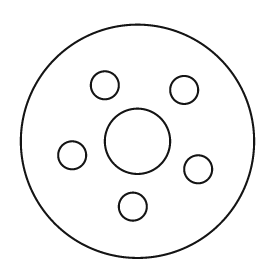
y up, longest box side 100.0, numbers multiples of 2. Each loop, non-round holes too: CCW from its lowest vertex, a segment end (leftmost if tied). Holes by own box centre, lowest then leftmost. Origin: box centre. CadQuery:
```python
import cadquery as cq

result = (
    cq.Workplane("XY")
    .moveTo(0.0, 0.0)
    .circle(50.0)
    .moveTo(-2.0, -28.0)
    .circle(6.0)
    .moveTo(26.0, -12.0)
    .circle(6.0)
    .moveTo(-28.0, -6.0)
    .circle(6.0)
    .moveTo(0.0, 0.0)
    .circle(14.0)
    .moveTo(20.0, 22.0)
    .circle(6.0)
    .moveTo(-14.0, 24.0)
    .circle(6.0)
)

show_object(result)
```